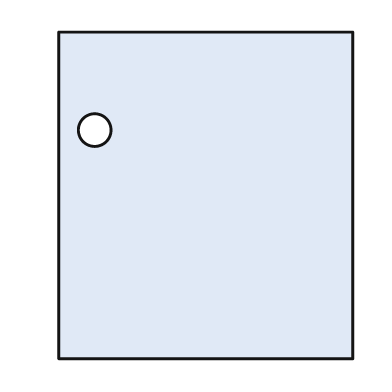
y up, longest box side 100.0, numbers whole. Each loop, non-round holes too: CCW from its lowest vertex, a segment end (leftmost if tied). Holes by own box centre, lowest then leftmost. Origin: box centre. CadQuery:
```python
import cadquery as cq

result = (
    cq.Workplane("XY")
    .moveTo(-45.0, -50.0)
    .lineTo(45.0, -50.0)
    .lineTo(45.0, 50.0)
    .lineTo(-45.0, 50.0)
    .close()
    .moveTo(-34.0, 20.0)
    .circle(5.0)
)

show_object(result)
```